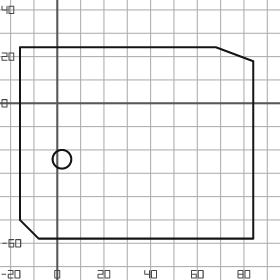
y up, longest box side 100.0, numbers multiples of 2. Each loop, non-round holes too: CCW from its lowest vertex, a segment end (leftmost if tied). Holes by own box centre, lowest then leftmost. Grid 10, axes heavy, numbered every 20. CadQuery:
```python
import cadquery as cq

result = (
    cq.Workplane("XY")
    .moveTo(-8.0, -58.0)
    .lineTo(84.0, -58.0)
    .lineTo(84.0, 18.0)
    .lineTo(68.0, 24.0)
    .lineTo(-16.0, 24.0)
    .lineTo(-16.0, -50.0)
    .close()
    .moveTo(2.0, -24.0)
    .circle(4.0)
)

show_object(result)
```